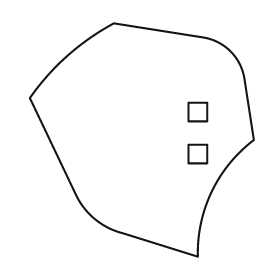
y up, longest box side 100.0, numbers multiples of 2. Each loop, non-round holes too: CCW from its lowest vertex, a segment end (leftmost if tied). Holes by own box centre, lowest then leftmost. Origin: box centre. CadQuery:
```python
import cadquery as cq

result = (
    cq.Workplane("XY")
    .moveTo(24.0, -50.0)
    .threePointArc((30.0, -22.0), (48.0, 0.0))
    .lineTo(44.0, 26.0)
    .threePointArc((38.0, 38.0), (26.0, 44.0))
    .lineTo(-12.0, 50.0)
    .threePointArc((-32.0, 36.0), (-48.0, 18.0))
    .lineTo(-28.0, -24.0)
    .threePointArc((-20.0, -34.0), (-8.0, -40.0))
    .close()
    .moveTo(20.0, -10.0)
    .lineTo(28.0, -10.0)
    .lineTo(28.0, -2.0)
    .lineTo(20.0, -2.0)
    .close()
    .moveTo(20.0, 8.0)
    .lineTo(28.0, 8.0)
    .lineTo(28.0, 16.0)
    .lineTo(20.0, 16.0)
    .close()
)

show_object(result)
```